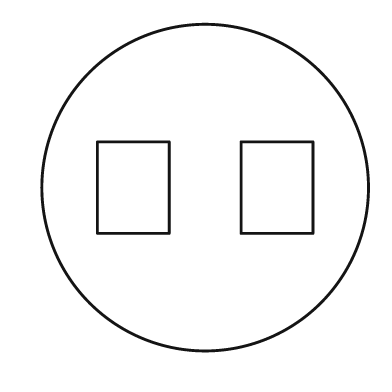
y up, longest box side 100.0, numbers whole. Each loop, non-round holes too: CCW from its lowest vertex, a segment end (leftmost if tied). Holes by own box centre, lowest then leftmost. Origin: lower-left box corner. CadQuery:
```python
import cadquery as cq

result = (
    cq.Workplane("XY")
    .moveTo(50.0, 50.0)
    .circle(50.0)
    .moveTo(17.0, 36.0)
    .lineTo(39.0, 36.0)
    .lineTo(39.0, 64.0)
    .lineTo(17.0, 64.0)
    .close()
    .moveTo(61.0, 36.0)
    .lineTo(83.0, 36.0)
    .lineTo(83.0, 64.0)
    .lineTo(61.0, 64.0)
    .close()
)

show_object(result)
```